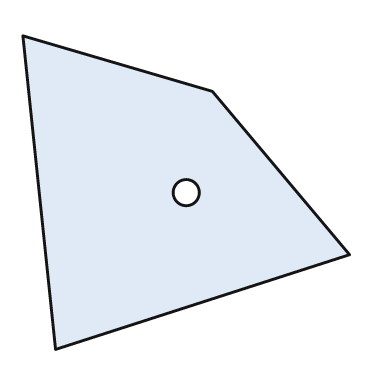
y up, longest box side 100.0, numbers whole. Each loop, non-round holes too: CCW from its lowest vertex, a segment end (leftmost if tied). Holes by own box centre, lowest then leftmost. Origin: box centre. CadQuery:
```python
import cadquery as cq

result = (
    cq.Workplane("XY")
    .moveTo(-40.0, -48.0)
    .lineTo(50.0, -19.0)
    .lineTo(8.0, 31.0)
    .lineTo(-50.0, 48.0)
    .close()
    .moveTo(0.0, 0.0)
    .circle(4.0)
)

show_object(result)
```